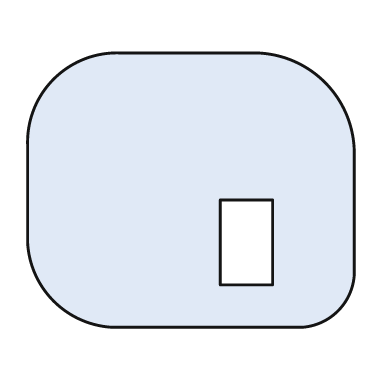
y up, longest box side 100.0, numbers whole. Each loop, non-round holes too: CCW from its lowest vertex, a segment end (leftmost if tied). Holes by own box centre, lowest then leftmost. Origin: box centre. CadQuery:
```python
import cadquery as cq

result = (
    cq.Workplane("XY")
    .moveTo(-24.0, -42.0)
    .lineTo(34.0, -42.0)
    .threePointArc((45.0, -37.0), (50.0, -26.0))
    .lineTo(50.0, 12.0)
    .threePointArc((41.0, 33.0), (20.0, 42.0))
    .lineTo(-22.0, 42.0)
    .threePointArc((-42.0, 34.0), (-50.0, 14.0))
    .lineTo(-50.0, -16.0)
    .threePointArc((-42.0, -34.0), (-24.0, -42.0))
    .close()
    .moveTo(9.0, -29.0)
    .lineTo(25.0, -29.0)
    .lineTo(25.0, -3.0)
    .lineTo(9.0, -3.0)
    .close()
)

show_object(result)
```